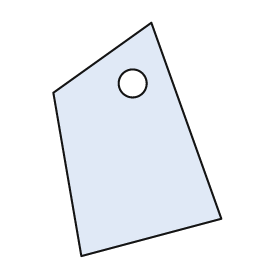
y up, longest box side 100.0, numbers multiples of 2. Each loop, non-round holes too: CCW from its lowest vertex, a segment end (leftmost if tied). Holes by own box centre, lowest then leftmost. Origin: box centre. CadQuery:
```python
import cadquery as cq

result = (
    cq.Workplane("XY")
    .moveTo(-24.0, -50.0)
    .lineTo(36.0, -34.0)
    .lineTo(6.0, 50.0)
    .lineTo(-36.0, 20.0)
    .close()
    .moveTo(-2.0, 24.0)
    .circle(6.0)
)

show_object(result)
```